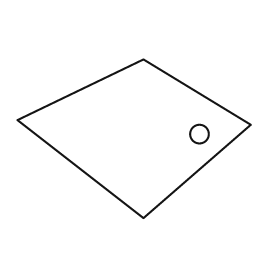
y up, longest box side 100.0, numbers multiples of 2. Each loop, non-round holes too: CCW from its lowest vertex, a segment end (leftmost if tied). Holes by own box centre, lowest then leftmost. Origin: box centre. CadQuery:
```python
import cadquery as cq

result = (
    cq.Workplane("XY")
    .moveTo(4.0, -34.0)
    .lineTo(50.0, 6.0)
    .lineTo(4.0, 34.0)
    .lineTo(-50.0, 8.0)
    .close()
    .moveTo(28.0, 2.0)
    .circle(4.0)
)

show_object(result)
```